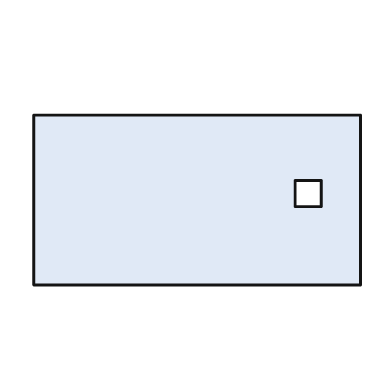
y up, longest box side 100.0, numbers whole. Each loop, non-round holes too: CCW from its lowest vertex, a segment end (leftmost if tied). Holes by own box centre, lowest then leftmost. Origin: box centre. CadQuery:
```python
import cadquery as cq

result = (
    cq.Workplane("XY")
    .moveTo(-50.0, -26.0)
    .lineTo(50.0, -26.0)
    .lineTo(50.0, 26.0)
    .lineTo(-50.0, 26.0)
    .close()
    .moveTo(30.0, -2.0)
    .lineTo(38.0, -2.0)
    .lineTo(38.0, 6.0)
    .lineTo(30.0, 6.0)
    .close()
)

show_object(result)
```